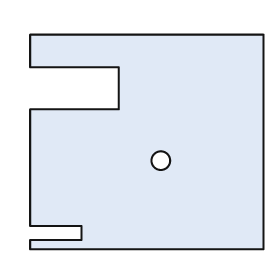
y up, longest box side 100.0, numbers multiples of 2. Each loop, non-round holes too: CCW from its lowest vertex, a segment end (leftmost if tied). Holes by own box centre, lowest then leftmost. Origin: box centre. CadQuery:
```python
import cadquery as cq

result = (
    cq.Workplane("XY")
    .moveTo(-50.0, -46.0)
    .lineTo(50.0, -46.0)
    .lineTo(50.0, 46.0)
    .lineTo(-50.0, 46.0)
    .lineTo(-50.0, 32.0)
    .lineTo(-12.0, 32.0)
    .lineTo(-12.0, 14.0)
    .lineTo(-50.0, 14.0)
    .lineTo(-50.0, -36.0)
    .lineTo(-28.0, -36.0)
    .lineTo(-28.0, -42.0)
    .lineTo(-50.0, -42.0)
    .close()
    .moveTo(6.0, -8.0)
    .circle(4.0)
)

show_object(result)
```